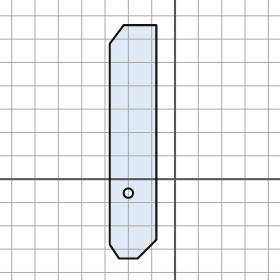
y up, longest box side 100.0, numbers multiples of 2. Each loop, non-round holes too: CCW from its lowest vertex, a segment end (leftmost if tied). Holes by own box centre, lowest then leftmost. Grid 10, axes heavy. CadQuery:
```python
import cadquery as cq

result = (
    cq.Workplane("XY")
    .moveTo(-24.0, -34.0)
    .lineTo(-16.0, -34.0)
    .lineTo(-8.0, -26.0)
    .lineTo(-8.0, 66.0)
    .lineTo(-22.0, 66.0)
    .lineTo(-28.0, 58.0)
    .lineTo(-28.0, -28.0)
    .close()
    .moveTo(-20.0, -6.0)
    .circle(2.0)
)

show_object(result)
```